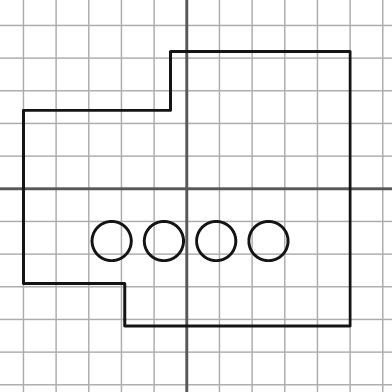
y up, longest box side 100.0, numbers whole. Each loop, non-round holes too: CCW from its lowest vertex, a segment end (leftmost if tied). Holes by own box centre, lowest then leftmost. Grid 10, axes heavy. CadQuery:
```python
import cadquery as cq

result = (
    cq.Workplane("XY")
    .moveTo(-19.0, -42.0)
    .lineTo(50.0, -42.0)
    .lineTo(50.0, 42.0)
    .lineTo(-5.0, 42.0)
    .lineTo(-5.0, 24.0)
    .lineTo(-50.0, 24.0)
    .lineTo(-50.0, -29.0)
    .lineTo(-19.0, -29.0)
    .close()
    .moveTo(-23.0, -16.0)
    .circle(6.0)
    .moveTo(-7.0, -16.0)
    .circle(6.0)
    .moveTo(9.0, -16.0)
    .circle(6.0)
    .moveTo(25.0, -16.0)
    .circle(6.0)
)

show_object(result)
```